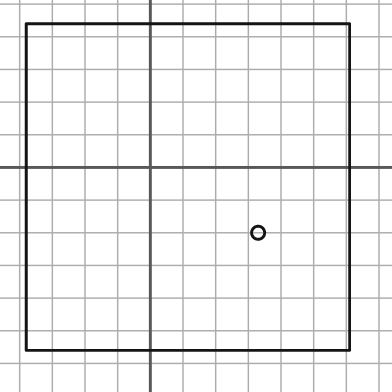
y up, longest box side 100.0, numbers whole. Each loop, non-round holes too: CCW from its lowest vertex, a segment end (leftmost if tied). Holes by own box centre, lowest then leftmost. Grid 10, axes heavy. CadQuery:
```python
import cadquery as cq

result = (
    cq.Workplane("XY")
    .moveTo(-38.0, -56.0)
    .lineTo(61.0, -56.0)
    .lineTo(61.0, 44.0)
    .lineTo(-38.0, 44.0)
    .close()
    .moveTo(33.0, -20.0)
    .circle(2.0)
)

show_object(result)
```